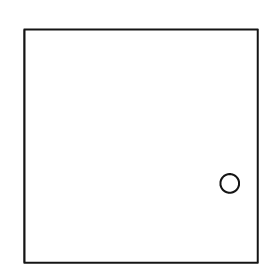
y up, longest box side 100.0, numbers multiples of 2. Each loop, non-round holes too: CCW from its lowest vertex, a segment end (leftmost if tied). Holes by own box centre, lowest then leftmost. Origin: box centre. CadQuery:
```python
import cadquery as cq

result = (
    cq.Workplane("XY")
    .moveTo(-50.0, -50.0)
    .lineTo(50.0, -50.0)
    .lineTo(50.0, 50.0)
    .lineTo(-50.0, 50.0)
    .close()
    .moveTo(38.0, -16.0)
    .circle(4.0)
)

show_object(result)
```